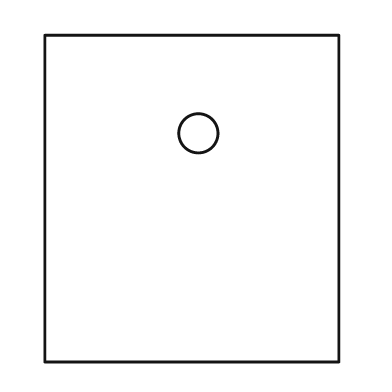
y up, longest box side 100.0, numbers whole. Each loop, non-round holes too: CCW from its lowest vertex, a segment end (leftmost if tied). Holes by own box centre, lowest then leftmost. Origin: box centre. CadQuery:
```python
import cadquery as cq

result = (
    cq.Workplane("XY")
    .moveTo(-45.0, -50.0)
    .lineTo(45.0, -50.0)
    .lineTo(45.0, 50.0)
    .lineTo(-45.0, 50.0)
    .close()
    .moveTo(2.0, 20.0)
    .circle(6.0)
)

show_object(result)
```